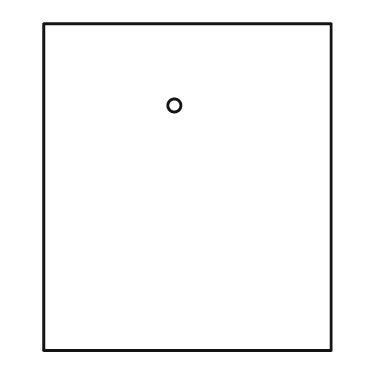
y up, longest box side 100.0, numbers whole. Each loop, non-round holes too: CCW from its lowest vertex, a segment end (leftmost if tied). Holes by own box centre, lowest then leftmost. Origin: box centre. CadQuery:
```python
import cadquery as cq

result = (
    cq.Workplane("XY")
    .moveTo(-44.0, -50.0)
    .lineTo(44.0, -50.0)
    .lineTo(44.0, 50.0)
    .lineTo(-44.0, 50.0)
    .close()
    .moveTo(-4.0, 25.0)
    .circle(2.0)
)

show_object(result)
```